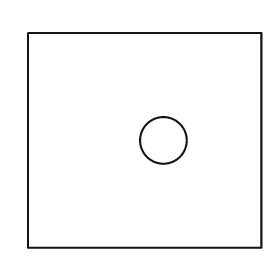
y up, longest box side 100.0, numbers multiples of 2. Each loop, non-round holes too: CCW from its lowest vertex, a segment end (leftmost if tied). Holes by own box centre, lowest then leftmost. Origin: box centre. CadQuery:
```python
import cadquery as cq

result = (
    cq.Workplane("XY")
    .moveTo(-50.0, -46.0)
    .lineTo(50.0, -46.0)
    .lineTo(50.0, 46.0)
    .lineTo(-50.0, 46.0)
    .close()
    .moveTo(8.0, 0.0)
    .circle(10.0)
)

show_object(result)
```